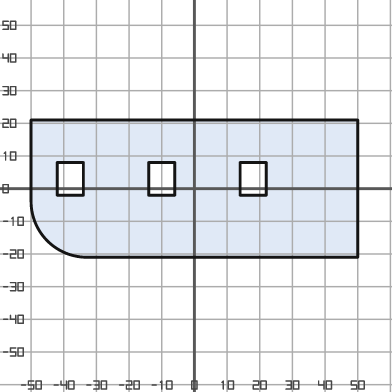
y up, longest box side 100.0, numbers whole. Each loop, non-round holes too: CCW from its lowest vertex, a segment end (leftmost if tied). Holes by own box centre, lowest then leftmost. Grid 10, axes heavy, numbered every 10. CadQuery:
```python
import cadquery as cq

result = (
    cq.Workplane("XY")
    .moveTo(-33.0, -21.0)
    .lineTo(50.0, -21.0)
    .lineTo(50.0, 21.0)
    .lineTo(-50.0, 21.0)
    .lineTo(-50.0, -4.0)
    .threePointArc((-45.0, -16.0), (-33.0, -21.0))
    .close()
    .moveTo(-42.0, -2.0)
    .lineTo(-34.0, -2.0)
    .lineTo(-34.0, 8.0)
    .lineTo(-42.0, 8.0)
    .close()
    .moveTo(-14.0, -2.0)
    .lineTo(-6.0, -2.0)
    .lineTo(-6.0, 8.0)
    .lineTo(-14.0, 8.0)
    .close()
    .moveTo(14.0, -2.0)
    .lineTo(22.0, -2.0)
    .lineTo(22.0, 8.0)
    .lineTo(14.0, 8.0)
    .close()
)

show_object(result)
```